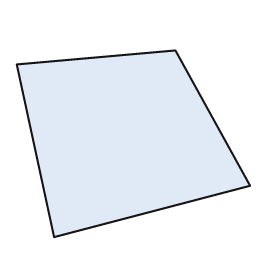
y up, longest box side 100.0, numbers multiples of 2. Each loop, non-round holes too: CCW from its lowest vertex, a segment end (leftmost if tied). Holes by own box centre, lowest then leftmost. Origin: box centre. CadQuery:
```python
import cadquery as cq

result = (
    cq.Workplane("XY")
    .moveTo(-34.0, -40.0)
    .lineTo(50.0, -18.0)
    .lineTo(18.0, 40.0)
    .lineTo(-50.0, 34.0)
    .close()
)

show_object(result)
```